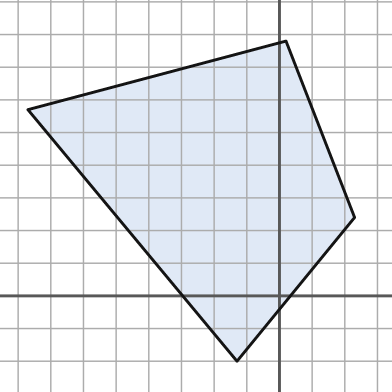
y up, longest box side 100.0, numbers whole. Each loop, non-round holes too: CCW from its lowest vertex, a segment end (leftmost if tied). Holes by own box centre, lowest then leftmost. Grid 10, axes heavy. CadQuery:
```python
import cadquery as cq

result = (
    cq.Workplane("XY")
    .moveTo(-13.0, -20.0)
    .lineTo(23.0, 24.0)
    .lineTo(2.0, 78.0)
    .lineTo(-77.0, 57.0)
    .close()
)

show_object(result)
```